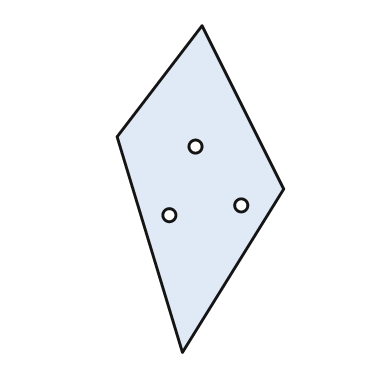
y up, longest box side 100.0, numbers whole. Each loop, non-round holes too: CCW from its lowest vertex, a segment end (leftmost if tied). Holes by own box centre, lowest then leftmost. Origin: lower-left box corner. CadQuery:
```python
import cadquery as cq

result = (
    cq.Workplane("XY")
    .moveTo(20.0, 0.0)
    .lineTo(51.0, 50.0)
    .lineTo(26.0, 100.0)
    .lineTo(0.0, 66.0)
    .close()
    .moveTo(16.0, 42.0)
    .circle(2.0)
    .moveTo(38.0, 45.0)
    .circle(2.0)
    .moveTo(24.0, 63.0)
    .circle(2.0)
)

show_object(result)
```